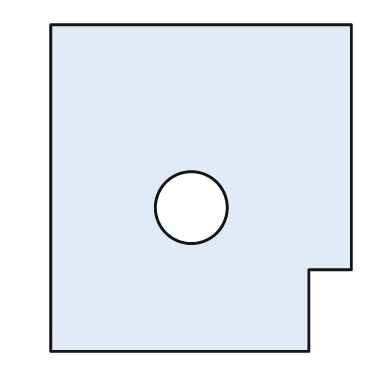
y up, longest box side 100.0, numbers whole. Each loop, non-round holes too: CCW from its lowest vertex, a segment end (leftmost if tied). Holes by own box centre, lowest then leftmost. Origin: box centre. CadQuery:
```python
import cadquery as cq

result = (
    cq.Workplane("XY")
    .moveTo(-46.0, -50.0)
    .lineTo(33.0, -50.0)
    .lineTo(33.0, -25.0)
    .lineTo(46.0, -25.0)
    .lineTo(46.0, 50.0)
    .lineTo(-46.0, 50.0)
    .close()
    .moveTo(-3.0, -6.0)
    .circle(11.0)
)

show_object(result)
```